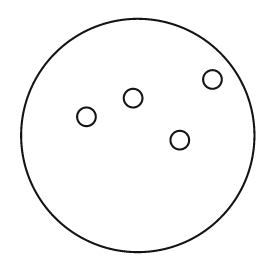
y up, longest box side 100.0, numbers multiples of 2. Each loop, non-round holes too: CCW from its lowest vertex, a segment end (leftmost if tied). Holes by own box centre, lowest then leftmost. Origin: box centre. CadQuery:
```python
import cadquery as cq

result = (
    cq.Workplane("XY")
    .moveTo(0.0, 0.0)
    .circle(50.0)
    .moveTo(18.0, -2.0)
    .circle(4.0)
    .moveTo(-22.0, 8.0)
    .circle(4.0)
    .moveTo(-2.0, 16.0)
    .circle(4.0)
    .moveTo(32.0, 24.0)
    .circle(4.0)
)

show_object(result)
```